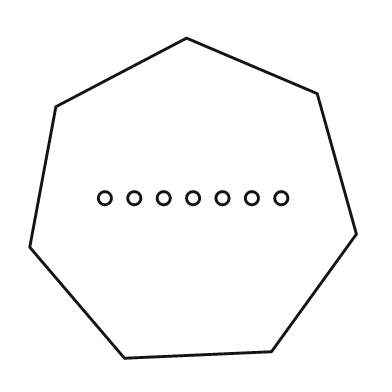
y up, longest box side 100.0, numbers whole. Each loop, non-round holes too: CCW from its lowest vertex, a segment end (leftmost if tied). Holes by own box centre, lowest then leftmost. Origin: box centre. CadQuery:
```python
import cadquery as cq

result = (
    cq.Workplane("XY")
    .moveTo(-21.0, -49.0)
    .lineTo(24.0, -47.0)
    .lineTo(50.0, -11.0)
    .lineTo(38.0, 32.0)
    .lineTo(-2.0, 49.0)
    .lineTo(-42.0, 28.0)
    .lineTo(-50.0, -15.0)
    .close()
    .moveTo(-27.0, 0.0)
    .circle(2.0)
    .moveTo(-18.0, 0.0)
    .circle(2.0)
    .moveTo(-9.0, 0.0)
    .circle(2.0)
    .moveTo(0.0, 0.0)
    .circle(2.0)
    .moveTo(9.0, 0.0)
    .circle(2.0)
    .moveTo(18.0, 0.0)
    .circle(2.0)
    .moveTo(27.0, 0.0)
    .circle(2.0)
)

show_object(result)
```